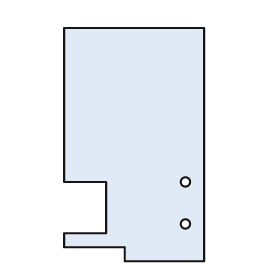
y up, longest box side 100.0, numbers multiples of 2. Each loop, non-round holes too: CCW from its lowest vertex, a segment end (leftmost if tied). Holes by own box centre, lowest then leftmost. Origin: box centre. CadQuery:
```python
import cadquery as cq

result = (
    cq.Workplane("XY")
    .moveTo(-4.0, -50.0)
    .lineTo(30.0, -50.0)
    .lineTo(30.0, 50.0)
    .lineTo(-30.0, 50.0)
    .lineTo(-30.0, -16.0)
    .lineTo(-12.0, -16.0)
    .lineTo(-12.0, -38.0)
    .lineTo(-30.0, -38.0)
    .lineTo(-30.0, -44.0)
    .lineTo(-4.0, -44.0)
    .close()
    .moveTo(22.0, -34.0)
    .circle(2.0)
    .moveTo(22.0, -16.0)
    .circle(2.0)
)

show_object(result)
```